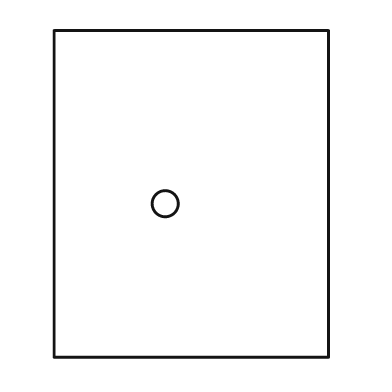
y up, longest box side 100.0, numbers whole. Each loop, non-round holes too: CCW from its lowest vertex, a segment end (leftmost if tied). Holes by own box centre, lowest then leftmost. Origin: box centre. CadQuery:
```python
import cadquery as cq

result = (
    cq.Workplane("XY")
    .moveTo(-42.0, -50.0)
    .lineTo(42.0, -50.0)
    .lineTo(42.0, 50.0)
    .lineTo(-42.0, 50.0)
    .close()
    .moveTo(-8.0, -3.0)
    .circle(4.0)
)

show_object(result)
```